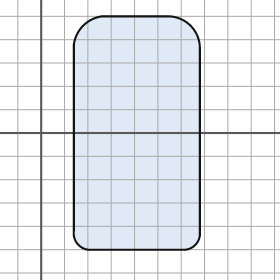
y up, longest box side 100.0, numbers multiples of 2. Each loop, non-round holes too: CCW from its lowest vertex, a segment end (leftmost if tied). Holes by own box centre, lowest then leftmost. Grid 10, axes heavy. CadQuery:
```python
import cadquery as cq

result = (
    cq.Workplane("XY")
    .moveTo(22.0, -50.0)
    .lineTo(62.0, -50.0)
    .threePointArc((66.0, -48.0), (68.0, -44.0))
    .lineTo(68.0, 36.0)
    .threePointArc((64.0, 46.0), (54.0, 50.0))
    .lineTo(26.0, 50.0)
    .threePointArc((18.0, 46.0), (14.0, 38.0))
    .lineTo(14.0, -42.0)
    .threePointArc((16.0, -48.0), (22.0, -50.0))
    .close()
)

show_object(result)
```